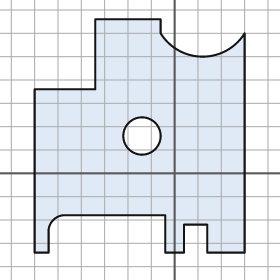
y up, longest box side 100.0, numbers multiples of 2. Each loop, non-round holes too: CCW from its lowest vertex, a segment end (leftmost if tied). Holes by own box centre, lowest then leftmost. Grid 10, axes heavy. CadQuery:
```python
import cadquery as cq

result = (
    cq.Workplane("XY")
    .moveTo(-60.0, -34.0)
    .lineTo(-54.0, -34.0)
    .lineTo(-54.0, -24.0)
    .threePointArc((-52.0, -20.0), (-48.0, -18.0))
    .lineTo(-4.0, -18.0)
    .lineTo(-4.0, -34.0)
    .lineTo(4.0, -34.0)
    .lineTo(4.0, -22.0)
    .lineTo(14.0, -22.0)
    .lineTo(14.0, -34.0)
    .lineTo(30.0, -34.0)
    .lineTo(30.0, 60.0)
    .threePointArc((12.0, 50.0), (-6.0, 60.0))
    .lineTo(-6.0, 66.0)
    .lineTo(-34.0, 66.0)
    .lineTo(-34.0, 36.0)
    .lineTo(-60.0, 36.0)
    .close()
    .moveTo(-14.0, 16.0)
    .circle(8.0)
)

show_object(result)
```